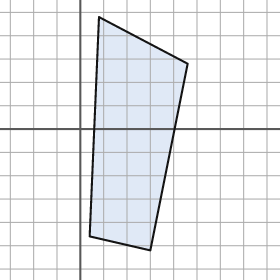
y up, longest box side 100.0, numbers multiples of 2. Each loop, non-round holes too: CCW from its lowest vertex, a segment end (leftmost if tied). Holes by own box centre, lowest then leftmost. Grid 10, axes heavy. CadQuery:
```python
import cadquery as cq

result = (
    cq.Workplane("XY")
    .moveTo(30.0, -52.0)
    .lineTo(46.0, 28.0)
    .lineTo(8.0, 48.0)
    .lineTo(4.0, -46.0)
    .close()
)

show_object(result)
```